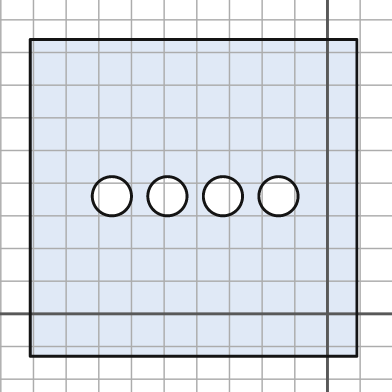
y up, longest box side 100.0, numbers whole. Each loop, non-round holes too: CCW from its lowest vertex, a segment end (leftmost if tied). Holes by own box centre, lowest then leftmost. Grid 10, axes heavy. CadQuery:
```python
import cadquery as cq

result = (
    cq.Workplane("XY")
    .moveTo(-91.0, -13.0)
    .lineTo(9.0, -13.0)
    .lineTo(9.0, 84.0)
    .lineTo(-91.0, 84.0)
    .close()
    .moveTo(-66.0, 36.0)
    .circle(6.0)
    .moveTo(-49.0, 36.0)
    .circle(6.0)
    .moveTo(-32.0, 36.0)
    .circle(6.0)
    .moveTo(-15.0, 36.0)
    .circle(6.0)
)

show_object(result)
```